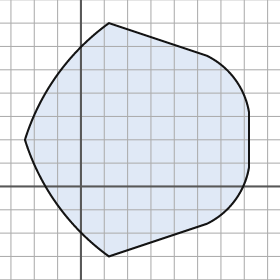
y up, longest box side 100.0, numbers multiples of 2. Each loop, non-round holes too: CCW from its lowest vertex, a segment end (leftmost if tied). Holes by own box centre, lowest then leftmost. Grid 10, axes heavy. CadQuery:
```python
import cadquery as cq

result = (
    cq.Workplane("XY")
    .moveTo(12.0, -30.0)
    .lineTo(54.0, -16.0)
    .threePointArc((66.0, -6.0), (72.0, 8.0))
    .lineTo(72.0, 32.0)
    .threePointArc((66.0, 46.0), (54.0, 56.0))
    .lineTo(12.0, 70.0)
    .threePointArc((-10.0, 48.0), (-24.0, 20.0))
    .threePointArc((-10.0, -8.0), (12.0, -30.0))
    .close()
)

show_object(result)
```